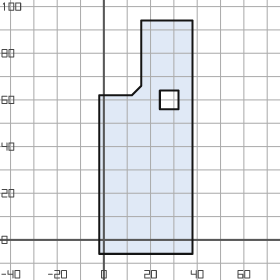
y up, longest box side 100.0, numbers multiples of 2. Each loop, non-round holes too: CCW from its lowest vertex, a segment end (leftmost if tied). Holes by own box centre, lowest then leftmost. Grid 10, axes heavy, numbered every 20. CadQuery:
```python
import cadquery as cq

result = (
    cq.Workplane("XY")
    .moveTo(-2.0, -6.0)
    .lineTo(38.0, -6.0)
    .lineTo(38.0, 94.0)
    .lineTo(16.0, 94.0)
    .lineTo(16.0, 66.0)
    .lineTo(12.0, 62.0)
    .lineTo(-2.0, 62.0)
    .close()
    .moveTo(24.0, 56.0)
    .lineTo(32.0, 56.0)
    .lineTo(32.0, 64.0)
    .lineTo(24.0, 64.0)
    .close()
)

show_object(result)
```